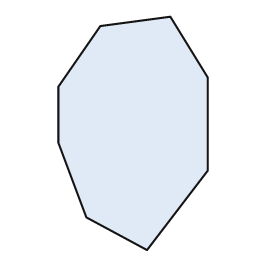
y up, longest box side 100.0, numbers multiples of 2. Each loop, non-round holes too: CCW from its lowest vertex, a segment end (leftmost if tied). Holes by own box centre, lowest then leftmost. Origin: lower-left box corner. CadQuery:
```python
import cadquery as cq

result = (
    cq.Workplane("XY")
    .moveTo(38.0, 0.0)
    .lineTo(64.0, 34.0)
    .lineTo(64.0, 74.0)
    .lineTo(48.0, 100.0)
    .lineTo(18.0, 96.0)
    .lineTo(0.0, 70.0)
    .lineTo(0.0, 46.0)
    .lineTo(12.0, 14.0)
    .close()
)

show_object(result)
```